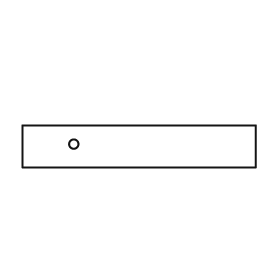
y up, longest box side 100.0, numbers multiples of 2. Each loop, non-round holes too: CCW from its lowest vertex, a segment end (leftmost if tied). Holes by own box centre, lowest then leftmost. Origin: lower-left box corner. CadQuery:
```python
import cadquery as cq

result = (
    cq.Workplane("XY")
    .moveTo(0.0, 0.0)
    .lineTo(100.0, 0.0)
    .lineTo(100.0, 18.0)
    .lineTo(0.0, 18.0)
    .close()
    .moveTo(22.0, 10.0)
    .circle(2.0)
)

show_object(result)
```